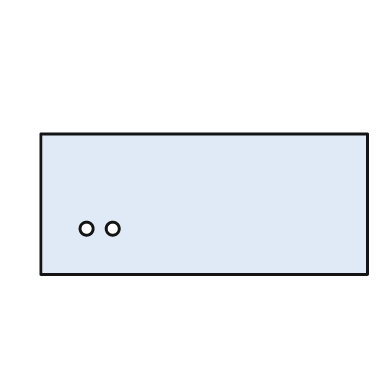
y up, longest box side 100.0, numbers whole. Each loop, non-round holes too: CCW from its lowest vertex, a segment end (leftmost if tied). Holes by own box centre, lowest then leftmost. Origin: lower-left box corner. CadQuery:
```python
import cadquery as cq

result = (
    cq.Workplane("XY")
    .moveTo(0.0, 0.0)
    .lineTo(100.0, 0.0)
    .lineTo(100.0, 43.0)
    .lineTo(0.0, 43.0)
    .close()
    .moveTo(14.0, 14.0)
    .circle(2.0)
    .moveTo(22.0, 14.0)
    .circle(2.0)
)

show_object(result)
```